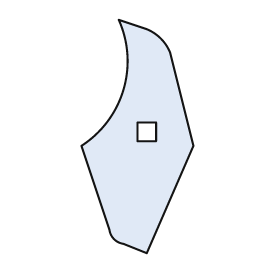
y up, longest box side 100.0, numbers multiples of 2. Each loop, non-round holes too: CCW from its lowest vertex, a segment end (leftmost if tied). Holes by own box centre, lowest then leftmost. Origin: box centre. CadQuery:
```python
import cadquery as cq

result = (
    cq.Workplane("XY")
    .moveTo(4.0, -50.0)
    .lineTo(24.0, -4.0)
    .lineTo(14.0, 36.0)
    .threePointArc((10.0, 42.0), (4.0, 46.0))
    .lineTo(-8.0, 50.0)
    .threePointArc((-6.0, 20.0), (-24.0, -4.0))
    .lineTo(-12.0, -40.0)
    .threePointArc((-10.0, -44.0), (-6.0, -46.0))
    .close()
    .moveTo(0.0, -2.0)
    .lineTo(8.0, -2.0)
    .lineTo(8.0, 6.0)
    .lineTo(0.0, 6.0)
    .close()
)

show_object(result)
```